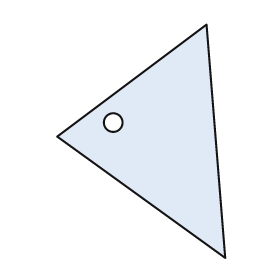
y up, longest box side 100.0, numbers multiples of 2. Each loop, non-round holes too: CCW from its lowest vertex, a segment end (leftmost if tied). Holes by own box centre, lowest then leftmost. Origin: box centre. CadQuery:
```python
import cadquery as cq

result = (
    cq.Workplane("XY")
    .moveTo(36.0, -50.0)
    .lineTo(28.0, 50.0)
    .lineTo(-36.0, 2.0)
    .close()
    .moveTo(-12.0, 8.0)
    .circle(4.0)
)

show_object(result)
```